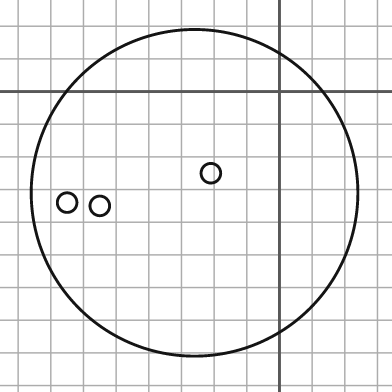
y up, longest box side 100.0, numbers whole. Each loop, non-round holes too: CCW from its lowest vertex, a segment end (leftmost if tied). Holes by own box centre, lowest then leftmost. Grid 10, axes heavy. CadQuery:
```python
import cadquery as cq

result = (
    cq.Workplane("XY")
    .moveTo(-26.0, -31.0)
    .circle(50.0)
    .moveTo(-55.0, -35.0)
    .circle(3.0)
    .moveTo(-65.0, -34.0)
    .circle(3.0)
    .moveTo(-21.0, -25.0)
    .circle(3.0)
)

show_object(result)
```